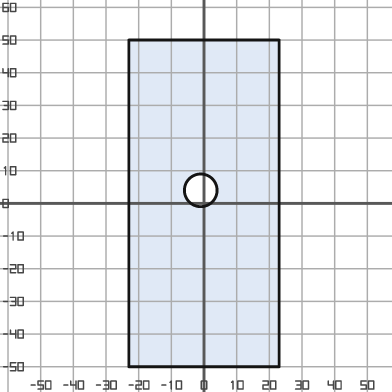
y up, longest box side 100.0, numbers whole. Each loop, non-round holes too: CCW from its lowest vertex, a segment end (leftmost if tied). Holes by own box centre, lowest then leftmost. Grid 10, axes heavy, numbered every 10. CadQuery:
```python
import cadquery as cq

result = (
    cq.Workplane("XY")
    .moveTo(-23.0, -50.0)
    .lineTo(23.0, -50.0)
    .lineTo(23.0, 50.0)
    .lineTo(-23.0, 50.0)
    .close()
    .moveTo(-1.0, 4.0)
    .circle(5.0)
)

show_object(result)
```